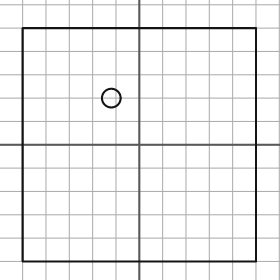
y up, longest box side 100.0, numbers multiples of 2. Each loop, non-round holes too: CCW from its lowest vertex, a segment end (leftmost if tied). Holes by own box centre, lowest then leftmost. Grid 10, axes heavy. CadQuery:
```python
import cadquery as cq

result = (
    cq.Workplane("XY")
    .moveTo(-50.0, -50.0)
    .lineTo(50.0, -50.0)
    .lineTo(50.0, 50.0)
    .lineTo(-50.0, 50.0)
    .close()
    .moveTo(-12.0, 20.0)
    .circle(4.0)
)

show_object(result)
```